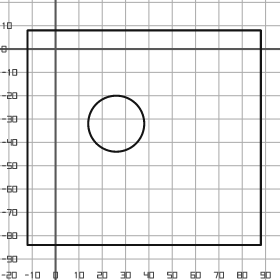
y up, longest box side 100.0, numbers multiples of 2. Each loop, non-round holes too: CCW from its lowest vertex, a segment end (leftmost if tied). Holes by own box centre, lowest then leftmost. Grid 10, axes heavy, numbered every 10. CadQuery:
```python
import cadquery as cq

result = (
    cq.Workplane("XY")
    .moveTo(-12.0, -84.0)
    .lineTo(88.0, -84.0)
    .lineTo(88.0, 8.0)
    .lineTo(-12.0, 8.0)
    .close()
    .moveTo(26.0, -32.0)
    .circle(12.0)
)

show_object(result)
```